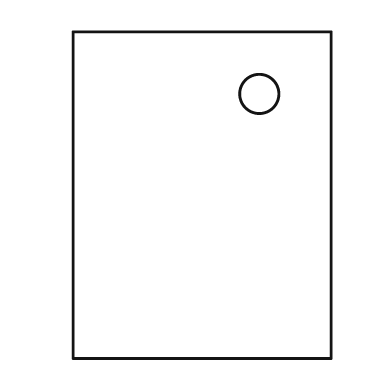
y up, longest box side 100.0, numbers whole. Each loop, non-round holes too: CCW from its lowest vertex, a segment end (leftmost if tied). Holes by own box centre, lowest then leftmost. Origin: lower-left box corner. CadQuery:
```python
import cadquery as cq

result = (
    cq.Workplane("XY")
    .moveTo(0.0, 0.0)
    .lineTo(79.0, 0.0)
    .lineTo(79.0, 100.0)
    .lineTo(0.0, 100.0)
    .close()
    .moveTo(57.0, 81.0)
    .circle(6.0)
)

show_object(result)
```